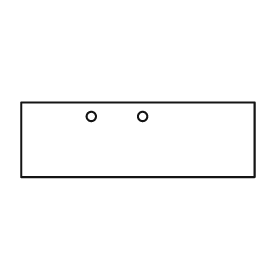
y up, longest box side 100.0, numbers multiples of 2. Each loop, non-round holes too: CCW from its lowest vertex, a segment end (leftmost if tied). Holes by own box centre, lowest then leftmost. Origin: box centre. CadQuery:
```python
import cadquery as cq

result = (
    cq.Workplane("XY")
    .moveTo(-50.0, -16.0)
    .lineTo(50.0, -16.0)
    .lineTo(50.0, 16.0)
    .lineTo(-50.0, 16.0)
    .close()
    .moveTo(-20.0, 10.0)
    .circle(2.0)
    .moveTo(2.0, 10.0)
    .circle(2.0)
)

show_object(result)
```